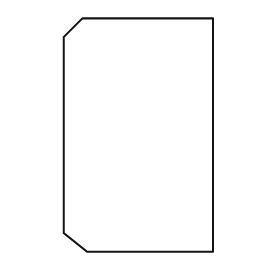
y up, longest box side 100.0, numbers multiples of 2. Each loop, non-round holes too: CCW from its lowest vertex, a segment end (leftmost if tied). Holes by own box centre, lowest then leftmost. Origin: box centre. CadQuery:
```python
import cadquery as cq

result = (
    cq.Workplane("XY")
    .moveTo(-22.0, -50.0)
    .lineTo(32.0, -50.0)
    .lineTo(32.0, 50.0)
    .lineTo(-24.0, 50.0)
    .lineTo(-32.0, 42.0)
    .lineTo(-32.0, -42.0)
    .close()
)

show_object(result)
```